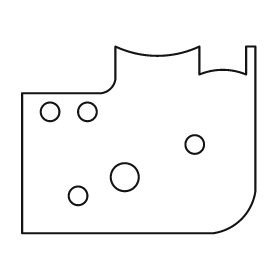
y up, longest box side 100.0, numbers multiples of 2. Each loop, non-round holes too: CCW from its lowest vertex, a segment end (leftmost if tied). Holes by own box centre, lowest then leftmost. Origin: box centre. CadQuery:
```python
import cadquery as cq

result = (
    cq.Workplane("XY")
    .moveTo(-50.0, -40.0)
    .lineTo(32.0, -40.0)
    .threePointArc((44.0, -34.0), (50.0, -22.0))
    .lineTo(50.0, 40.0)
    .lineTo(46.0, 40.0)
    .lineTo(46.0, 28.0)
    .threePointArc((36.0, 30.0), (26.0, 28.0))
    .lineTo(26.0, 40.0)
    .threePointArc((8.0, 36.0), (-10.0, 40.0))
    .lineTo(-10.0, 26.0)
    .threePointArc((-12.0, 22.0), (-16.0, 20.0))
    .lineTo(-50.0, 20.0)
    .close()
    .moveTo(-26.0, -24.0)
    .circle(4.0)
    .moveTo(-6.0, -16.0)
    .circle(6.0)
    .moveTo(24.0, -2.0)
    .circle(4.0)
    .moveTo(-38.0, 12.0)
    .circle(4.0)
    .moveTo(-22.0, 12.0)
    .circle(4.0)
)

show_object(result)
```